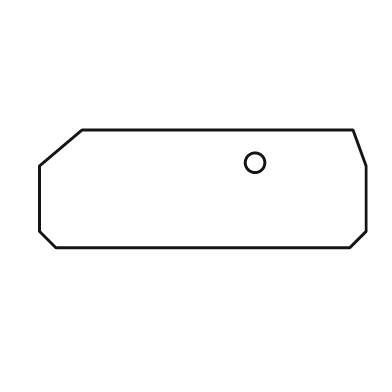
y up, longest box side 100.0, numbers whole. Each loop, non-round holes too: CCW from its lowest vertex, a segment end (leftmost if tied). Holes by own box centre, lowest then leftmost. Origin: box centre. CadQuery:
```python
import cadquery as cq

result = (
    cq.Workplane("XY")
    .moveTo(-45.0, -18.0)
    .lineTo(45.0, -18.0)
    .lineTo(50.0, -13.0)
    .lineTo(50.0, 7.0)
    .lineTo(46.0, 18.0)
    .lineTo(-37.0, 18.0)
    .lineTo(-50.0, 7.0)
    .lineTo(-50.0, -13.0)
    .close()
    .moveTo(16.0, 8.0)
    .circle(3.0)
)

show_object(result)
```